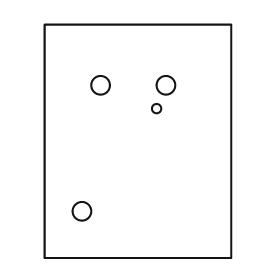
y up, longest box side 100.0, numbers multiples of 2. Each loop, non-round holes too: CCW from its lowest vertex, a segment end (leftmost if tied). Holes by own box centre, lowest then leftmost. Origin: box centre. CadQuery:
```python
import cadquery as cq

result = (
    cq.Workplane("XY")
    .moveTo(-40.0, -50.0)
    .lineTo(40.0, -50.0)
    .lineTo(40.0, 50.0)
    .lineTo(-40.0, 50.0)
    .close()
    .moveTo(-24.0, -30.0)
    .circle(4.0)
    .moveTo(8.0, 14.0)
    .circle(2.0)
    .moveTo(-16.0, 24.0)
    .circle(4.0)
    .moveTo(12.0, 24.0)
    .circle(4.0)
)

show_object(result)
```